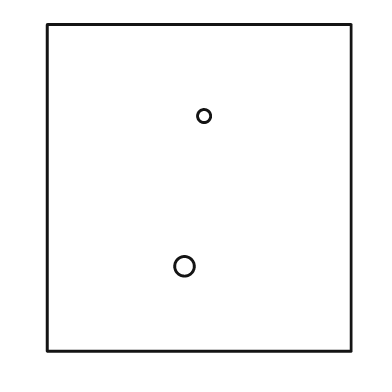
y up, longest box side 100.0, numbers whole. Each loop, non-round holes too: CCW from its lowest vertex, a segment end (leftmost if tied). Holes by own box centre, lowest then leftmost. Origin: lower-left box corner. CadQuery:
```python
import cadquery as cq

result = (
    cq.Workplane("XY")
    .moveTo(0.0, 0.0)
    .lineTo(93.0, 0.0)
    .lineTo(93.0, 100.0)
    .lineTo(0.0, 100.0)
    .close()
    .moveTo(42.0, 26.0)
    .circle(3.0)
    .moveTo(48.0, 72.0)
    .circle(2.0)
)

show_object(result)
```